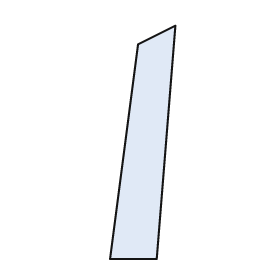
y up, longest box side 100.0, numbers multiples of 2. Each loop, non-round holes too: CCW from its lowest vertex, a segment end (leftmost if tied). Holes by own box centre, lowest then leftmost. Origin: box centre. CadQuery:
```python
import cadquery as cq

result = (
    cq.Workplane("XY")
    .moveTo(-14.0, -50.0)
    .lineTo(6.0, -50.0)
    .lineTo(14.0, 50.0)
    .lineTo(-2.0, 42.0)
    .close()
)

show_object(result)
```